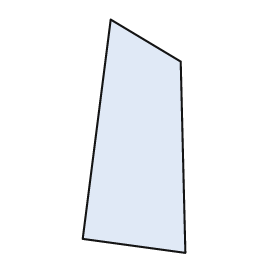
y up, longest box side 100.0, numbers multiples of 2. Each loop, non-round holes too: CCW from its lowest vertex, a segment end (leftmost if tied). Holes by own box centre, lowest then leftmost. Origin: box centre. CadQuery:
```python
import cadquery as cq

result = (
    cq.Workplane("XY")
    .moveTo(22.0, -50.0)
    .lineTo(20.0, 32.0)
    .lineTo(-10.0, 50.0)
    .lineTo(-22.0, -44.0)
    .close()
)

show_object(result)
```